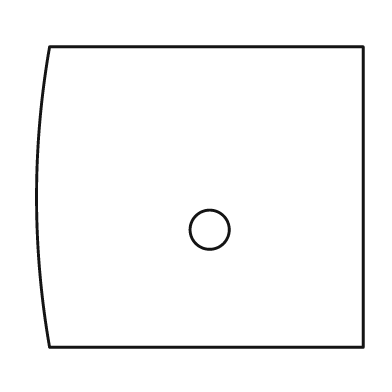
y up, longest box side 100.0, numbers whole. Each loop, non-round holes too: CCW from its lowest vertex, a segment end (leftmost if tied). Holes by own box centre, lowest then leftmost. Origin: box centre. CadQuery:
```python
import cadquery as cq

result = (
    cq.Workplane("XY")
    .moveTo(-46.0, -46.0)
    .lineTo(50.0, -46.0)
    .lineTo(50.0, 46.0)
    .lineTo(-46.0, 46.0)
    .threePointArc((-50.0, 0.0), (-46.0, -46.0))
    .close()
    .moveTo(3.0, -10.0)
    .circle(6.0)
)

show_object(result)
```